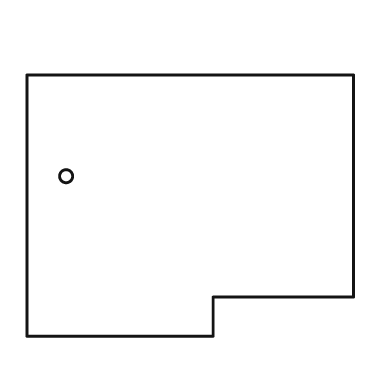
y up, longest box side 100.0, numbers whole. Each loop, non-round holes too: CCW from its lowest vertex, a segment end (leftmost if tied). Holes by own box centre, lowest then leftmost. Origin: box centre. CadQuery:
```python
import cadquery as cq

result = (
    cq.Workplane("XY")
    .moveTo(-50.0, -40.0)
    .lineTo(7.0, -40.0)
    .lineTo(7.0, -28.0)
    .lineTo(50.0, -28.0)
    .lineTo(50.0, 40.0)
    .lineTo(-50.0, 40.0)
    .close()
    .moveTo(-38.0, 9.0)
    .circle(2.0)
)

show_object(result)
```